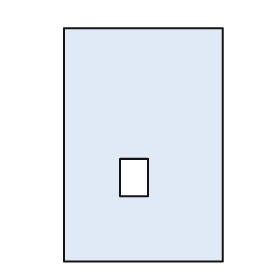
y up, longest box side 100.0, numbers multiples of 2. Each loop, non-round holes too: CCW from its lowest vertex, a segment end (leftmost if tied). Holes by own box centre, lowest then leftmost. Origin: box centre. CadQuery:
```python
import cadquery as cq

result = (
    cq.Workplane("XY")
    .moveTo(-34.0, -50.0)
    .lineTo(34.0, -50.0)
    .lineTo(34.0, 50.0)
    .lineTo(-34.0, 50.0)
    .close()
    .moveTo(-10.0, -22.0)
    .lineTo(2.0, -22.0)
    .lineTo(2.0, -6.0)
    .lineTo(-10.0, -6.0)
    .close()
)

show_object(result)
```